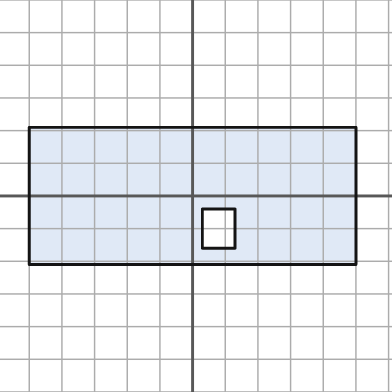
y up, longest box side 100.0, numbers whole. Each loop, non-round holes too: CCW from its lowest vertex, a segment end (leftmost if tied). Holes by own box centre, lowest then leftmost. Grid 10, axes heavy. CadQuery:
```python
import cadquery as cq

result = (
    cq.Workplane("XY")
    .moveTo(-50.0, -21.0)
    .lineTo(50.0, -21.0)
    .lineTo(50.0, 21.0)
    .lineTo(-50.0, 21.0)
    .close()
    .moveTo(3.0, -16.0)
    .lineTo(13.0, -16.0)
    .lineTo(13.0, -4.0)
    .lineTo(3.0, -4.0)
    .close()
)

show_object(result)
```